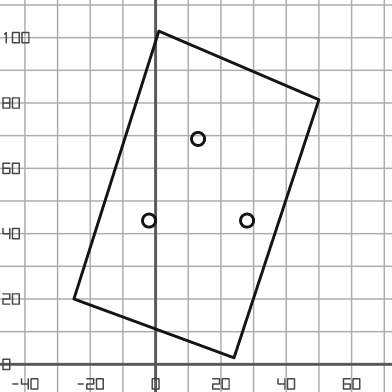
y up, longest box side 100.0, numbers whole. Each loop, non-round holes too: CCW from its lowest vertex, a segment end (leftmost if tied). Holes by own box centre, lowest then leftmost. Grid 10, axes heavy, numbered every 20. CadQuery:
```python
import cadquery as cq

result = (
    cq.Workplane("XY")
    .moveTo(24.0, 2.0)
    .lineTo(50.0, 81.0)
    .lineTo(1.0, 102.0)
    .lineTo(-25.0, 20.0)
    .close()
    .moveTo(-2.0, 44.0)
    .circle(2.0)
    .moveTo(28.0, 44.0)
    .circle(2.0)
    .moveTo(13.0, 69.0)
    .circle(2.0)
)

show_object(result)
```